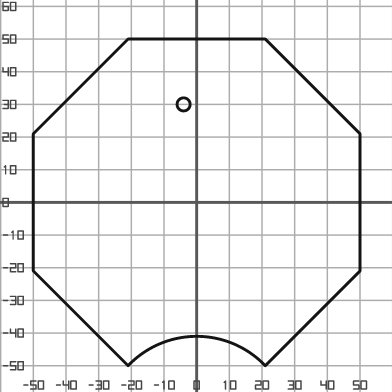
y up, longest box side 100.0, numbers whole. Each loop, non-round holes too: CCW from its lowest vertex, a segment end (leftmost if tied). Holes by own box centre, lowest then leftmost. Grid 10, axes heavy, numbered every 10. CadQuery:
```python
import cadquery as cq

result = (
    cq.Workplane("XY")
    .moveTo(-21.0, -50.0)
    .threePointArc((0.0, -41.0), (21.0, -50.0))
    .lineTo(50.0, -21.0)
    .lineTo(50.0, 21.0)
    .lineTo(21.0, 50.0)
    .lineTo(-21.0, 50.0)
    .lineTo(-50.0, 21.0)
    .lineTo(-50.0, -21.0)
    .close()
    .moveTo(-4.0, 30.0)
    .circle(2.0)
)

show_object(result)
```